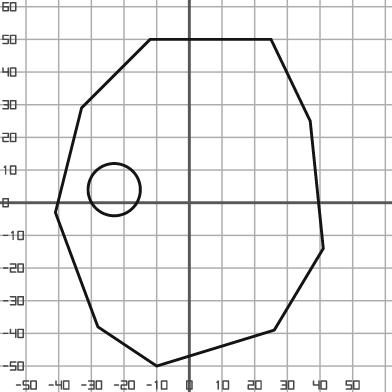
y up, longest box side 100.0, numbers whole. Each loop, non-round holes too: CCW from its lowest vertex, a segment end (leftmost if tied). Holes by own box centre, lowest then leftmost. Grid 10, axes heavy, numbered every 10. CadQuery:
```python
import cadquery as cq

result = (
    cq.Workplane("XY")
    .moveTo(-10.0, -50.0)
    .lineTo(26.0, -39.0)
    .lineTo(41.0, -14.0)
    .lineTo(37.0, 25.0)
    .lineTo(25.0, 50.0)
    .lineTo(-12.0, 50.0)
    .lineTo(-33.0, 29.0)
    .lineTo(-41.0, -3.0)
    .lineTo(-28.0, -38.0)
    .close()
    .moveTo(-23.0, 4.0)
    .circle(8.0)
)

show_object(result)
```